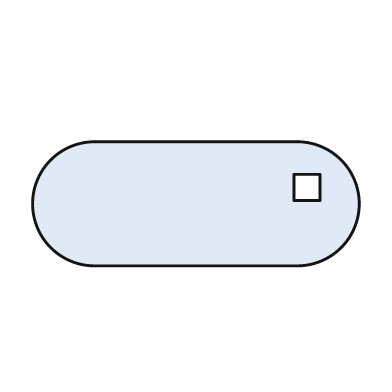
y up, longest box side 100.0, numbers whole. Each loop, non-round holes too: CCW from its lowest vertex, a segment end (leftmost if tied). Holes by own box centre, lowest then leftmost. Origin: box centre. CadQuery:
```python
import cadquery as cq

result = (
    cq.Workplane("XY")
    .moveTo(-31.0, -19.0)
    .lineTo(31.0, -19.0)
    .threePointArc((50.0, 0.0), (31.0, 19.0))
    .lineTo(-31.0, 19.0)
    .threePointArc((-50.0, 0.0), (-31.0, -19.0))
    .close()
    .moveTo(30.0, 1.0)
    .lineTo(38.0, 1.0)
    .lineTo(38.0, 9.0)
    .lineTo(30.0, 9.0)
    .close()
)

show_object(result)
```